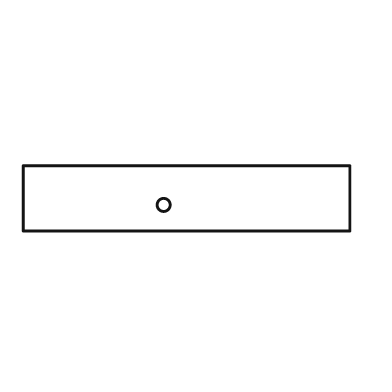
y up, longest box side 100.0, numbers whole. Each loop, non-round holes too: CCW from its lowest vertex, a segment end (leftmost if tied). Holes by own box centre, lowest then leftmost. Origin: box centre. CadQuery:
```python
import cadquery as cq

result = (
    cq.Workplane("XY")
    .moveTo(-50.0, -10.0)
    .lineTo(50.0, -10.0)
    .lineTo(50.0, 10.0)
    .lineTo(-50.0, 10.0)
    .close()
    .moveTo(-7.0, -2.0)
    .circle(2.0)
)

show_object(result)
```